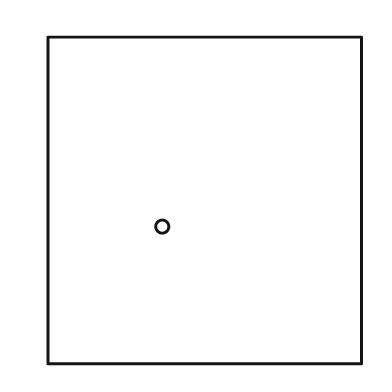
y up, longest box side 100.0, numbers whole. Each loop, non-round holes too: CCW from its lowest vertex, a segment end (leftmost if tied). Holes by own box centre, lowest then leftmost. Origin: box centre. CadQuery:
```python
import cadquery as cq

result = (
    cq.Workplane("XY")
    .moveTo(-48.0, -50.0)
    .lineTo(48.0, -50.0)
    .lineTo(48.0, 50.0)
    .lineTo(-48.0, 50.0)
    .close()
    .moveTo(-13.0, -8.0)
    .circle(2.0)
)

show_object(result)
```